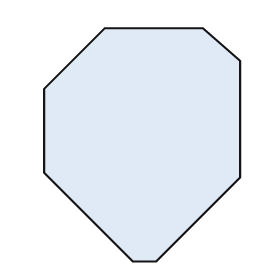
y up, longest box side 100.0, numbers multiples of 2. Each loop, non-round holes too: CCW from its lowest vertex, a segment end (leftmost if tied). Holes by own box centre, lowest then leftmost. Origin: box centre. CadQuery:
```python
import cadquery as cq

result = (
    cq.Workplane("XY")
    .moveTo(-4.0, -50.0)
    .lineTo(6.0, -50.0)
    .lineTo(42.0, -14.0)
    .lineTo(42.0, 36.0)
    .lineTo(26.0, 50.0)
    .lineTo(-16.0, 50.0)
    .lineTo(-42.0, 24.0)
    .lineTo(-42.0, -12.0)
    .close()
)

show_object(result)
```